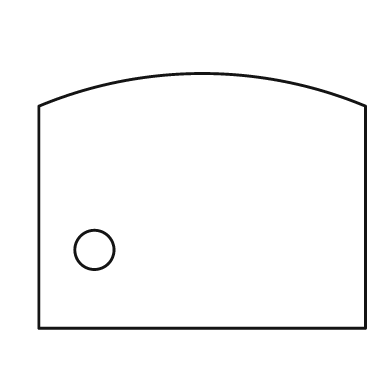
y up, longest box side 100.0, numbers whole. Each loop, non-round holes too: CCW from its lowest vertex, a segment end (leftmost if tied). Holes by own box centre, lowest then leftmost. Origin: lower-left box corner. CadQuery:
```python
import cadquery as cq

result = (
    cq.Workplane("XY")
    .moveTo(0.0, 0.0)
    .lineTo(100.0, 0.0)
    .lineTo(100.0, 68.0)
    .threePointArc((50.0, 78.0), (0.0, 68.0))
    .close()
    .moveTo(17.0, 24.0)
    .circle(6.0)
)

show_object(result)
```